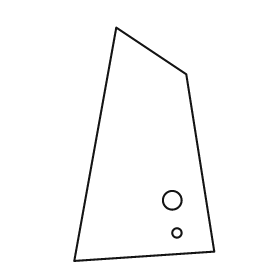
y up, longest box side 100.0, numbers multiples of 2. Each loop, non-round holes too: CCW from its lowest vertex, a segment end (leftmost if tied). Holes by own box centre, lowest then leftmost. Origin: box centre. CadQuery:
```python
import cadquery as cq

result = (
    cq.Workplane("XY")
    .moveTo(-30.0, -50.0)
    .lineTo(30.0, -46.0)
    .lineTo(18.0, 30.0)
    .lineTo(-12.0, 50.0)
    .close()
    .moveTo(14.0, -38.0)
    .circle(2.0)
    .moveTo(12.0, -24.0)
    .circle(4.0)
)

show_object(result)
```